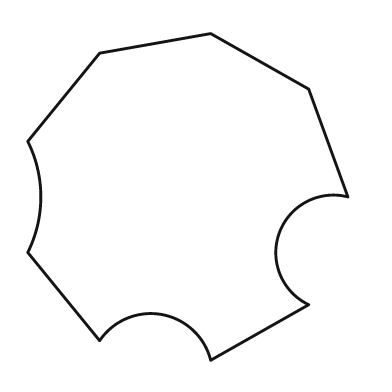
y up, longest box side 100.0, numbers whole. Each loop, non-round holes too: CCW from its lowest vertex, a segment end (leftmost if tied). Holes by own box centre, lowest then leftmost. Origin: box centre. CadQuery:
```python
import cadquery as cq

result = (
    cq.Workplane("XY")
    .moveTo(7.0, -50.0)
    .lineTo(37.0, -33.0)
    .threePointArc((28.0, -11.0), (49.0, 0.0))
    .lineTo(37.0, 33.0)
    .lineTo(7.0, 50.0)
    .lineTo(-27.0, 44.0)
    .lineTo(-49.0, 17.0)
    .threePointArc((-45.0, 0.0), (-49.0, -17.0))
    .lineTo(-27.0, -44.0)
    .threePointArc((-8.0, -36.0), (7.0, -50.0))
    .close()
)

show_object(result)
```